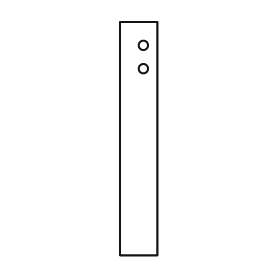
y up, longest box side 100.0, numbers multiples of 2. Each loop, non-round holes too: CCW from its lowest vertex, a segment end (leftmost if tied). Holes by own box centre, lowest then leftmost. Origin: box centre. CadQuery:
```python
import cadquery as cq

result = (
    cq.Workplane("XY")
    .moveTo(-8.0, -50.0)
    .lineTo(8.0, -50.0)
    .lineTo(8.0, 50.0)
    .lineTo(-8.0, 50.0)
    .close()
    .moveTo(2.0, 30.0)
    .circle(2.0)
    .moveTo(2.0, 40.0)
    .circle(2.0)
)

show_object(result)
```